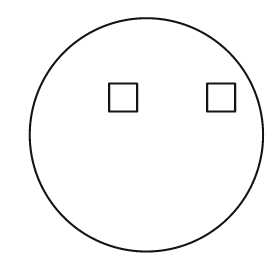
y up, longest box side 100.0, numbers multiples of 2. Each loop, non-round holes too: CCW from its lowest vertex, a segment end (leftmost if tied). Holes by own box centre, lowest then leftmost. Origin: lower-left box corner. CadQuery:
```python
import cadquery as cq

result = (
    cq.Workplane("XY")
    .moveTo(50.0, 50.0)
    .circle(50.0)
    .moveTo(34.0, 60.0)
    .lineTo(46.0, 60.0)
    .lineTo(46.0, 72.0)
    .lineTo(34.0, 72.0)
    .close()
    .moveTo(76.0, 60.0)
    .lineTo(88.0, 60.0)
    .lineTo(88.0, 72.0)
    .lineTo(76.0, 72.0)
    .close()
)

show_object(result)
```